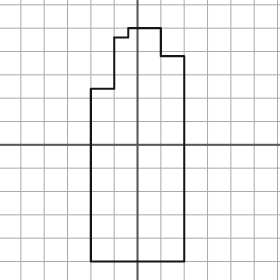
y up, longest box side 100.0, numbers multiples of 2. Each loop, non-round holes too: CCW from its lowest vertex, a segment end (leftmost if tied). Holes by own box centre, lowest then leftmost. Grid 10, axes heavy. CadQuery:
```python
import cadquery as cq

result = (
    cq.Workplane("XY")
    .moveTo(-20.0, -50.0)
    .lineTo(20.0, -50.0)
    .lineTo(20.0, 38.0)
    .lineTo(10.0, 38.0)
    .lineTo(10.0, 50.0)
    .lineTo(-4.0, 50.0)
    .lineTo(-4.0, 46.0)
    .lineTo(-10.0, 46.0)
    .lineTo(-10.0, 24.0)
    .lineTo(-20.0, 24.0)
    .close()
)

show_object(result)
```